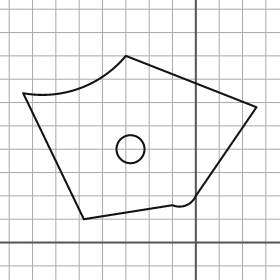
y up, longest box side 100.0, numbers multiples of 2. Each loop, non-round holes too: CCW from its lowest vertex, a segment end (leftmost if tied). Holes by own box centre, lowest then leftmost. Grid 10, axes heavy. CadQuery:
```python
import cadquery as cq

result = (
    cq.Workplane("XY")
    .moveTo(-48.0, 10.0)
    .lineTo(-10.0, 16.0)
    .threePointArc((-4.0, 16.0), (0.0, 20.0))
    .lineTo(26.0, 58.0)
    .lineTo(-30.0, 80.0)
    .threePointArc((-50.0, 66.0), (-74.0, 64.0))
    .close()
    .moveTo(-28.0, 40.0)
    .circle(6.0)
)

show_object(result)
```